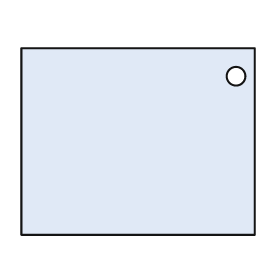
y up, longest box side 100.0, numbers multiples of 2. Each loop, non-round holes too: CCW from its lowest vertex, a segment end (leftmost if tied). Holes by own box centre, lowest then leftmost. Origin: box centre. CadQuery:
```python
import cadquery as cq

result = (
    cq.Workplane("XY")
    .moveTo(-50.0, -40.0)
    .lineTo(50.0, -40.0)
    .lineTo(50.0, 40.0)
    .lineTo(-50.0, 40.0)
    .close()
    .moveTo(42.0, 28.0)
    .circle(4.0)
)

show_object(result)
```